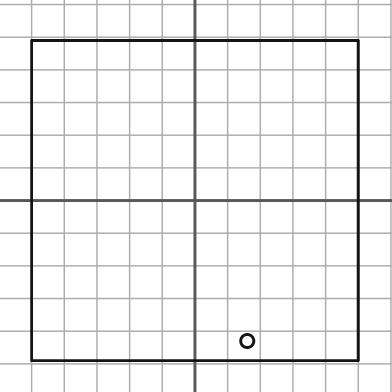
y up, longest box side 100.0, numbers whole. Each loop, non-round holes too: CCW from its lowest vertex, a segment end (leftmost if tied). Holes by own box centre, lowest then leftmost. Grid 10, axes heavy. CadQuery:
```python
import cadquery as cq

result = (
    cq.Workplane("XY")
    .moveTo(-50.0, -49.0)
    .lineTo(50.0, -49.0)
    .lineTo(50.0, 49.0)
    .lineTo(-50.0, 49.0)
    .close()
    .moveTo(16.0, -43.0)
    .circle(2.0)
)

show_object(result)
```